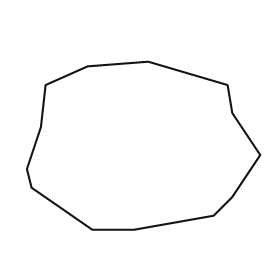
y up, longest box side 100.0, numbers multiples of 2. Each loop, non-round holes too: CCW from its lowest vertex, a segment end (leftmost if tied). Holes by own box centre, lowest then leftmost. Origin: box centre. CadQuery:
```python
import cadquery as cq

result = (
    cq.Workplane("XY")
    .moveTo(-22.0, -36.0)
    .lineTo(-4.0, -36.0)
    .lineTo(30.0, -30.0)
    .lineTo(38.0, -22.0)
    .lineTo(50.0, -4.0)
    .lineTo(38.0, 14.0)
    .lineTo(36.0, 26.0)
    .lineTo(2.0, 36.0)
    .lineTo(-24.0, 34.0)
    .lineTo(-42.0, 26.0)
    .lineTo(-44.0, 8.0)
    .lineTo(-50.0, -10.0)
    .lineTo(-48.0, -18.0)
    .close()
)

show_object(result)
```